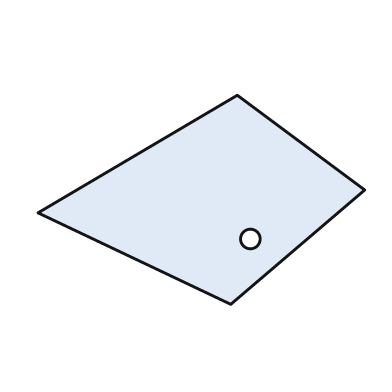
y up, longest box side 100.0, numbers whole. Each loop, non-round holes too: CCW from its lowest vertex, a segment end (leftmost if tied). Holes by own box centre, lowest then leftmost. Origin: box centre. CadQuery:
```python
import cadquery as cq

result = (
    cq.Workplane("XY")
    .moveTo(9.0, -32.0)
    .lineTo(50.0, 3.0)
    .lineTo(11.0, 32.0)
    .lineTo(-50.0, -4.0)
    .close()
    .moveTo(15.0, -12.0)
    .circle(3.0)
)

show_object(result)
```